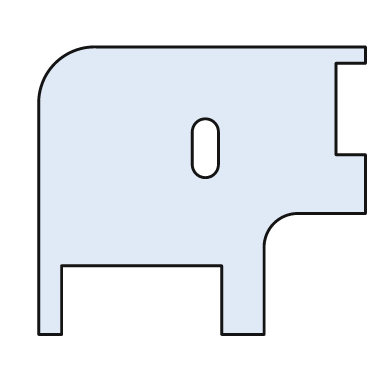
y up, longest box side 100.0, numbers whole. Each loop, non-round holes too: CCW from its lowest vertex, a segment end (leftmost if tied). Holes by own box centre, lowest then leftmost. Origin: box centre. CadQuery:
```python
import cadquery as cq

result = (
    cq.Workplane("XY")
    .moveTo(-50.0, -44.0)
    .lineTo(-43.0, -44.0)
    .lineTo(-43.0, -23.0)
    .lineTo(6.0, -23.0)
    .lineTo(6.0, -44.0)
    .lineTo(19.0, -44.0)
    .lineTo(19.0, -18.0)
    .threePointArc((22.0, -10.0), (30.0, -7.0))
    .lineTo(50.0, -7.0)
    .lineTo(50.0, 11.0)
    .lineTo(41.0, 11.0)
    .lineTo(41.0, 39.0)
    .lineTo(50.0, 39.0)
    .lineTo(50.0, 44.0)
    .lineTo(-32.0, 44.0)
    .threePointArc((-45.0, 39.0), (-50.0, 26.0))
    .close()
    .moveTo(-3.0, 8.0)
    .threePointArc((1.0, 4.0), (5.0, 8.0))
    .lineTo(5.0, 18.0)
    .threePointArc((1.0, 22.0), (-3.0, 18.0))
    .close()
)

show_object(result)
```